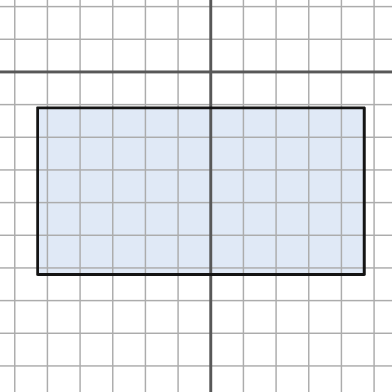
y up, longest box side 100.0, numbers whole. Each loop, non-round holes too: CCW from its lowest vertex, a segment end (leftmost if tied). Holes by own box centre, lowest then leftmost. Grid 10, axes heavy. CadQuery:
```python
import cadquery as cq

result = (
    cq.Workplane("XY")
    .moveTo(-53.0, -62.0)
    .lineTo(47.0, -62.0)
    .lineTo(47.0, -11.0)
    .lineTo(-53.0, -11.0)
    .close()
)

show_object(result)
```